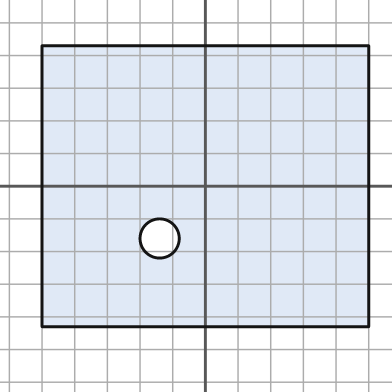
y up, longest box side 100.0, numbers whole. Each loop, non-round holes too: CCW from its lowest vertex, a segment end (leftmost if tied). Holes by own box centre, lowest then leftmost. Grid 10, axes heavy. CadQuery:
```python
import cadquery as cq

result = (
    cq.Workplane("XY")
    .moveTo(-50.0, -43.0)
    .lineTo(50.0, -43.0)
    .lineTo(50.0, 43.0)
    .lineTo(-50.0, 43.0)
    .close()
    .moveTo(-14.0, -16.0)
    .circle(6.0)
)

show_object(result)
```